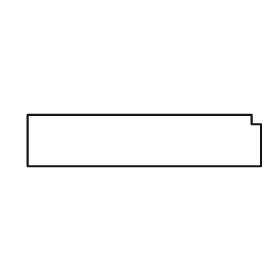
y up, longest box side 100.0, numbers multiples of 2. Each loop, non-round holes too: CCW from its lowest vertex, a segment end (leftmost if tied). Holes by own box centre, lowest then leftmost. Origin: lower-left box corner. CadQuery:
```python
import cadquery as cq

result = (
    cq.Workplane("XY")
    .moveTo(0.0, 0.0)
    .lineTo(100.0, 0.0)
    .lineTo(100.0, 18.0)
    .lineTo(96.0, 18.0)
    .lineTo(96.0, 22.0)
    .lineTo(0.0, 22.0)
    .close()
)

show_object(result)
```